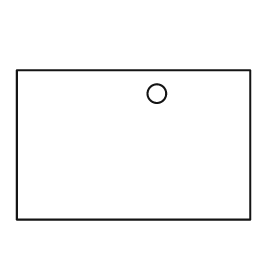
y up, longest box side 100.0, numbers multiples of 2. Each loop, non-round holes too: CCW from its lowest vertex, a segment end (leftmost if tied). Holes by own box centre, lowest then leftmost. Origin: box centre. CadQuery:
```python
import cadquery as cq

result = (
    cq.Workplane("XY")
    .moveTo(-50.0, -32.0)
    .lineTo(50.0, -32.0)
    .lineTo(50.0, 32.0)
    .lineTo(-50.0, 32.0)
    .close()
    .moveTo(10.0, 22.0)
    .circle(4.0)
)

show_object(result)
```